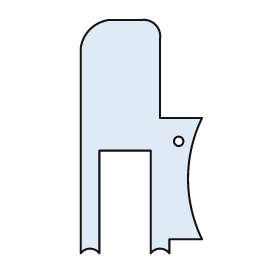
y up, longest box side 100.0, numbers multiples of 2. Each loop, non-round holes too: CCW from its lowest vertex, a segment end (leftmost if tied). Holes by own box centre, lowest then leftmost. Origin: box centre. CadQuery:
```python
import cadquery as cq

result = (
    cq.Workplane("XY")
    .moveTo(-26.0, -50.0)
    .threePointArc((-22.0, -48.0), (-18.0, -50.0))
    .lineTo(-18.0, -6.0)
    .lineTo(4.0, -6.0)
    .lineTo(4.0, -50.0)
    .threePointArc((8.0, -48.0), (12.0, -50.0))
    .lineTo(12.0, -44.0)
    .lineTo(26.0, -44.0)
    .threePointArc((20.0, -18.0), (26.0, 8.0))
    .lineTo(8.0, 8.0)
    .lineTo(8.0, 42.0)
    .threePointArc((6.0, 48.0), (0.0, 50.0))
    .lineTo(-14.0, 50.0)
    .threePointArc((-22.0, 46.0), (-26.0, 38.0))
    .close()
    .moveTo(16.0, -2.0)
    .circle(2.0)
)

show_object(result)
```